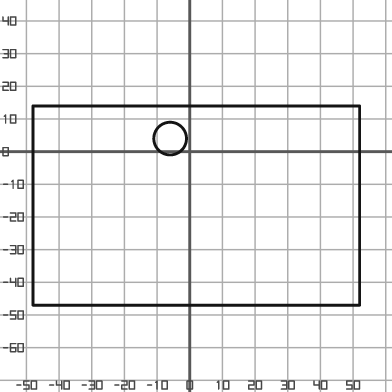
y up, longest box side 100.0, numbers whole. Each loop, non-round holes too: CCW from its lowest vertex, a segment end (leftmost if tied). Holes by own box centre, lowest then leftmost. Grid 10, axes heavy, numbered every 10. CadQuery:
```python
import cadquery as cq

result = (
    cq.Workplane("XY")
    .moveTo(-48.0, -47.0)
    .lineTo(52.0, -47.0)
    .lineTo(52.0, 14.0)
    .lineTo(-48.0, 14.0)
    .close()
    .moveTo(-6.0, 4.0)
    .circle(5.0)
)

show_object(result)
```